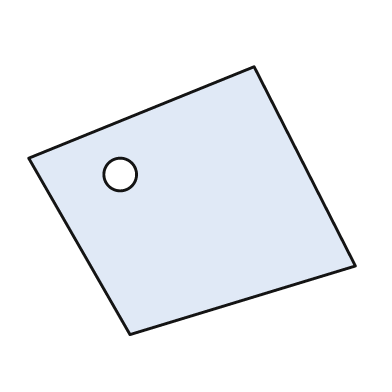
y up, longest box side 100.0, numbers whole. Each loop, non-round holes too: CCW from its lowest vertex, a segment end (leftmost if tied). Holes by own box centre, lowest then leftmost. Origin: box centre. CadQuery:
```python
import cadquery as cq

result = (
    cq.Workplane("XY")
    .moveTo(-19.0, -41.0)
    .lineTo(50.0, -20.0)
    .lineTo(19.0, 41.0)
    .lineTo(-50.0, 13.0)
    .close()
    .moveTo(-22.0, 8.0)
    .circle(5.0)
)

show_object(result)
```